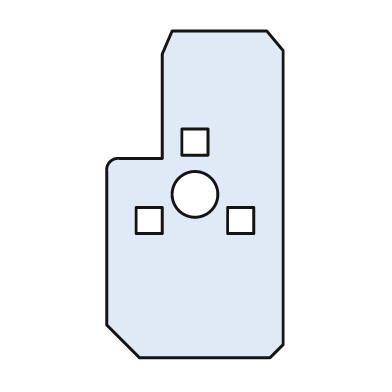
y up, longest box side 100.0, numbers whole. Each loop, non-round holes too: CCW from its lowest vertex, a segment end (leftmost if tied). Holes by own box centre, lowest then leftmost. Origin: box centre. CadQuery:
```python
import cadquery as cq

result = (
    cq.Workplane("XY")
    .moveTo(-17.0, -50.0)
    .lineTo(23.0, -50.0)
    .lineTo(27.0, -46.0)
    .lineTo(27.0, 44.0)
    .lineTo(22.0, 50.0)
    .lineTo(-7.0, 50.0)
    .lineTo(-10.0, 43.0)
    .lineTo(-10.0, 11.0)
    .lineTo(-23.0, 11.0)
    .threePointArc((-26.0, 10.0), (-27.0, 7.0))
    .lineTo(-27.0, -40.0)
    .close()
    .moveTo(-18.0, -12.0)
    .lineTo(-10.0, -12.0)
    .lineTo(-10.0, -4.0)
    .lineTo(-18.0, -4.0)
    .close()
    .moveTo(10.0, -12.0)
    .lineTo(18.0, -12.0)
    .lineTo(18.0, -4.0)
    .lineTo(10.0, -4.0)
    .close()
    .moveTo(0.0, 0.0)
    .circle(7.0)
    .moveTo(-4.0, 12.0)
    .lineTo(4.0, 12.0)
    .lineTo(4.0, 20.0)
    .lineTo(-4.0, 20.0)
    .close()
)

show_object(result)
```